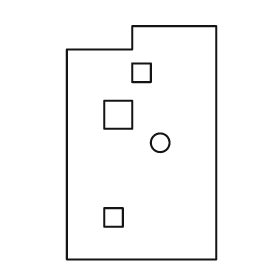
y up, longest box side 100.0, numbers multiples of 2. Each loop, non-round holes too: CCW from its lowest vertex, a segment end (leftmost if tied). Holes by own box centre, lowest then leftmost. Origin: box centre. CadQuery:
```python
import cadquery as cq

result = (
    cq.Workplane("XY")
    .moveTo(-32.0, -50.0)
    .lineTo(32.0, -50.0)
    .lineTo(32.0, 50.0)
    .lineTo(-4.0, 50.0)
    .lineTo(-4.0, 40.0)
    .lineTo(-32.0, 40.0)
    .close()
    .moveTo(-16.0, -36.0)
    .lineTo(-8.0, -36.0)
    .lineTo(-8.0, -28.0)
    .lineTo(-16.0, -28.0)
    .close()
    .moveTo(8.0, 0.0)
    .circle(4.0)
    .moveTo(-16.0, 6.0)
    .lineTo(-4.0, 6.0)
    .lineTo(-4.0, 18.0)
    .lineTo(-16.0, 18.0)
    .close()
    .moveTo(-4.0, 26.0)
    .lineTo(4.0, 26.0)
    .lineTo(4.0, 34.0)
    .lineTo(-4.0, 34.0)
    .close()
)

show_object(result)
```